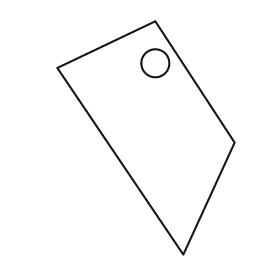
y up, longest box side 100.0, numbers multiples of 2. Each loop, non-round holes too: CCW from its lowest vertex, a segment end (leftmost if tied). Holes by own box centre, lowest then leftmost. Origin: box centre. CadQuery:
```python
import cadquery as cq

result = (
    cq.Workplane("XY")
    .moveTo(16.0, -50.0)
    .lineTo(38.0, -2.0)
    .lineTo(4.0, 50.0)
    .lineTo(-38.0, 30.0)
    .close()
    .moveTo(4.0, 32.0)
    .circle(6.0)
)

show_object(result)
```